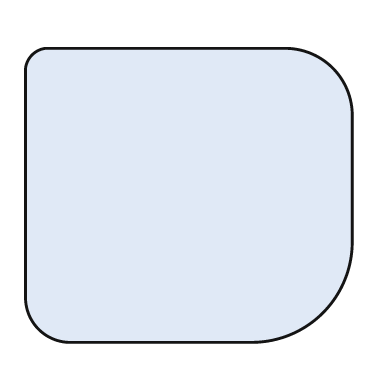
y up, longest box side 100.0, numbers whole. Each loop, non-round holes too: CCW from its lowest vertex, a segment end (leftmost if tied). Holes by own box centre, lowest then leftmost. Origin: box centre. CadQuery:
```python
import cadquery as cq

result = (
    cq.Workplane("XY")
    .moveTo(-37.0, -45.0)
    .lineTo(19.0, -45.0)
    .threePointArc((41.0, -36.0), (50.0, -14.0))
    .lineTo(50.0, 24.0)
    .threePointArc((44.0, 39.0), (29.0, 45.0))
    .lineTo(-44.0, 45.0)
    .threePointArc((-48.0, 43.0), (-50.0, 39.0))
    .lineTo(-50.0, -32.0)
    .threePointArc((-46.0, -41.0), (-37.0, -45.0))
    .close()
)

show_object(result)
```